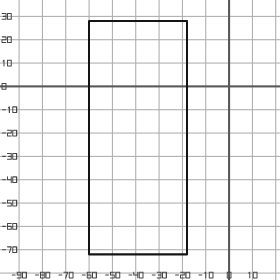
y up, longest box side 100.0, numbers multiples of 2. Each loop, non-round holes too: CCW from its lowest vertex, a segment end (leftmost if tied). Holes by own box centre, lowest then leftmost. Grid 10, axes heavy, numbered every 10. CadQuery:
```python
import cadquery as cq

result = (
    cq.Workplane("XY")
    .moveTo(-60.0, -72.0)
    .lineTo(-18.0, -72.0)
    .lineTo(-18.0, 28.0)
    .lineTo(-60.0, 28.0)
    .close()
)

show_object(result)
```